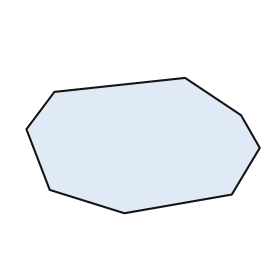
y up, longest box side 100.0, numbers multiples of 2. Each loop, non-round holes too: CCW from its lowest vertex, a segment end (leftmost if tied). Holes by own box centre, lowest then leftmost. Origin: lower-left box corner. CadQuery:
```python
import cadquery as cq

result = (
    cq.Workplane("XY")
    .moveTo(42.0, 0.0)
    .lineTo(88.0, 8.0)
    .lineTo(100.0, 28.0)
    .lineTo(92.0, 42.0)
    .lineTo(68.0, 58.0)
    .lineTo(12.0, 52.0)
    .lineTo(0.0, 36.0)
    .lineTo(10.0, 10.0)
    .close()
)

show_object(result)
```